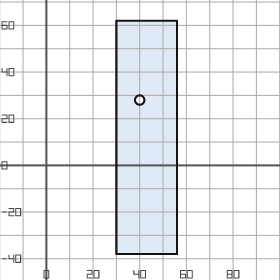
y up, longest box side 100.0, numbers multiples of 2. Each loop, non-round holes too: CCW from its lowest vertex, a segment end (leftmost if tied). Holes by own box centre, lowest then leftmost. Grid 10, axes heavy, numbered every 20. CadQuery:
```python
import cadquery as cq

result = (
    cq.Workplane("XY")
    .moveTo(30.0, -38.0)
    .lineTo(56.0, -38.0)
    .lineTo(56.0, 62.0)
    .lineTo(30.0, 62.0)
    .close()
    .moveTo(40.0, 28.0)
    .circle(2.0)
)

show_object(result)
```